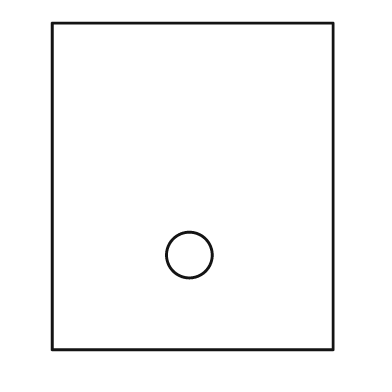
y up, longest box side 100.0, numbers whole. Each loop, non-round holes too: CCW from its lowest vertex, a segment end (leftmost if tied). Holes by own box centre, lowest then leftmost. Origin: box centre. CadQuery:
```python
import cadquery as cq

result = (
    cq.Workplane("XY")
    .moveTo(-43.0, -50.0)
    .lineTo(43.0, -50.0)
    .lineTo(43.0, 50.0)
    .lineTo(-43.0, 50.0)
    .close()
    .moveTo(-1.0, -21.0)
    .circle(7.0)
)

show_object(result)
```